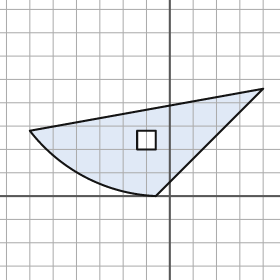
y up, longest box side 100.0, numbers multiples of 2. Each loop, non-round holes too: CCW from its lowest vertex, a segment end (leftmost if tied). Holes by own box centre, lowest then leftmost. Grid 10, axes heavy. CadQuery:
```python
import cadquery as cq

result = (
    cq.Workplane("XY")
    .moveTo(-6.0, 0.0)
    .lineTo(40.0, 46.0)
    .lineTo(-60.0, 28.0)
    .threePointArc((-36.0, 8.0), (-6.0, 0.0))
    .close()
    .moveTo(-14.0, 20.0)
    .lineTo(-6.0, 20.0)
    .lineTo(-6.0, 28.0)
    .lineTo(-14.0, 28.0)
    .close()
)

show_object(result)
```